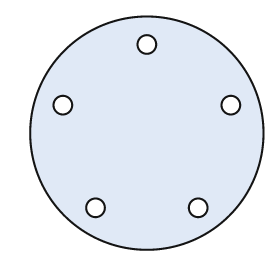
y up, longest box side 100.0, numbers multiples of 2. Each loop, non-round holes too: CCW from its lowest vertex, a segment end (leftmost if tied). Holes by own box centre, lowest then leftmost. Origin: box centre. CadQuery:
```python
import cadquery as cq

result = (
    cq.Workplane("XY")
    .moveTo(0.0, 0.0)
    .circle(50.0)
    .moveTo(-22.0, -32.0)
    .circle(4.0)
    .moveTo(22.0, -32.0)
    .circle(4.0)
    .moveTo(-36.0, 12.0)
    .circle(4.0)
    .moveTo(36.0, 12.0)
    .circle(4.0)
    .moveTo(0.0, 38.0)
    .circle(4.0)
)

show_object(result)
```